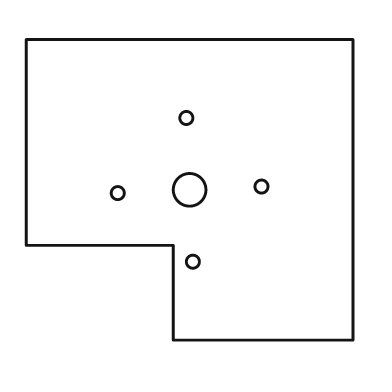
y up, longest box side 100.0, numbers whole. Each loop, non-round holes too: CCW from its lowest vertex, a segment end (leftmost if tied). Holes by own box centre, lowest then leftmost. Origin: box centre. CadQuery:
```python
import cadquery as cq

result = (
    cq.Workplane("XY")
    .moveTo(-5.0, -46.0)
    .lineTo(50.0, -46.0)
    .lineTo(50.0, 46.0)
    .lineTo(-50.0, 46.0)
    .lineTo(-50.0, -17.0)
    .lineTo(-5.0, -17.0)
    .close()
    .moveTo(1.0, -22.0)
    .circle(2.0)
    .moveTo(-22.0, -1.0)
    .circle(2.0)
    .moveTo(0.0, 0.0)
    .circle(5.0)
    .moveTo(22.0, 1.0)
    .circle(2.0)
    .moveTo(-1.0, 22.0)
    .circle(2.0)
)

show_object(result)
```